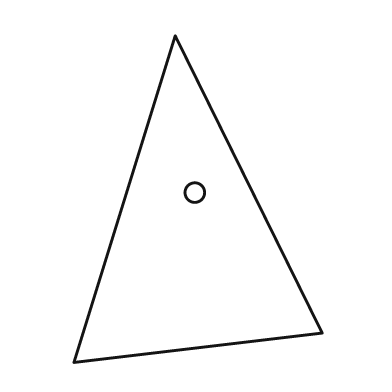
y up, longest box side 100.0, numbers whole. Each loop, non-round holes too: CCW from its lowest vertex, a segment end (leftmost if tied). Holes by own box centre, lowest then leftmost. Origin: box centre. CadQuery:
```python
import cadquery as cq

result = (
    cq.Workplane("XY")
    .moveTo(-38.0, -50.0)
    .lineTo(38.0, -41.0)
    .lineTo(-7.0, 50.0)
    .close()
    .moveTo(-1.0, 2.0)
    .circle(3.0)
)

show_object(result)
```